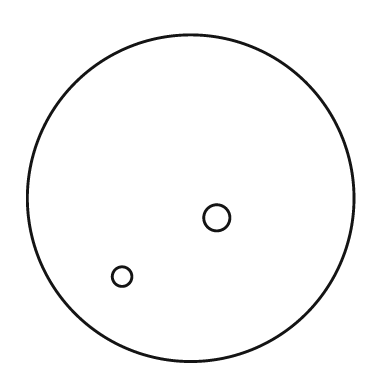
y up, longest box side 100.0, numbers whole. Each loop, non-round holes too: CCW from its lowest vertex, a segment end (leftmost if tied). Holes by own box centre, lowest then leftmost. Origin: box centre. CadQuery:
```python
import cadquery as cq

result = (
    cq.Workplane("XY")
    .moveTo(0.0, 0.0)
    .circle(50.0)
    .moveTo(-21.0, -24.0)
    .circle(3.0)
    .moveTo(8.0, -6.0)
    .circle(4.0)
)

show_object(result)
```